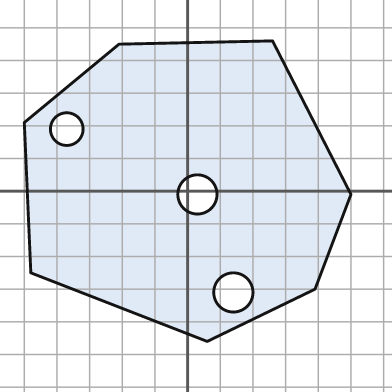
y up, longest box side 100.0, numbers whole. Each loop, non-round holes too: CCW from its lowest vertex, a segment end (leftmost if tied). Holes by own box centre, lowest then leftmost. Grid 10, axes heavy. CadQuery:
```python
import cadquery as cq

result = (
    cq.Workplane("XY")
    .moveTo(6.0, -46.0)
    .lineTo(39.0, -30.0)
    .lineTo(50.0, -1.0)
    .lineTo(26.0, 46.0)
    .lineTo(-21.0, 45.0)
    .lineTo(-50.0, 21.0)
    .lineTo(-48.0, -25.0)
    .close()
    .moveTo(14.0, -31.0)
    .circle(6.0)
    .moveTo(3.0, -1.0)
    .circle(6.0)
    .moveTo(-37.0, 19.0)
    .circle(5.0)
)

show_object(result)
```